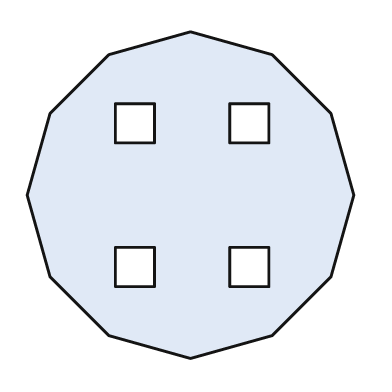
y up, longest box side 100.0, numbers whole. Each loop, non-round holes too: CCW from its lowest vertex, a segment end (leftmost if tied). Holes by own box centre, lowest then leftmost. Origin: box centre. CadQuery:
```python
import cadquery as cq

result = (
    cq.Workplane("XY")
    .moveTo(0.0, -50.0)
    .lineTo(25.0, -43.0)
    .lineTo(43.0, -25.0)
    .lineTo(50.0, 0.0)
    .lineTo(43.0, 25.0)
    .lineTo(25.0, 43.0)
    .lineTo(0.0, 50.0)
    .lineTo(-25.0, 43.0)
    .lineTo(-43.0, 25.0)
    .lineTo(-50.0, 0.0)
    .lineTo(-43.0, -25.0)
    .lineTo(-25.0, -43.0)
    .close()
    .moveTo(-23.0, -28.0)
    .lineTo(-11.0, -28.0)
    .lineTo(-11.0, -16.0)
    .lineTo(-23.0, -16.0)
    .close()
    .moveTo(12.0, -28.0)
    .lineTo(24.0, -28.0)
    .lineTo(24.0, -16.0)
    .lineTo(12.0, -16.0)
    .close()
    .moveTo(-23.0, 16.0)
    .lineTo(-11.0, 16.0)
    .lineTo(-11.0, 28.0)
    .lineTo(-23.0, 28.0)
    .close()
    .moveTo(12.0, 16.0)
    .lineTo(24.0, 16.0)
    .lineTo(24.0, 28.0)
    .lineTo(12.0, 28.0)
    .close()
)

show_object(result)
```